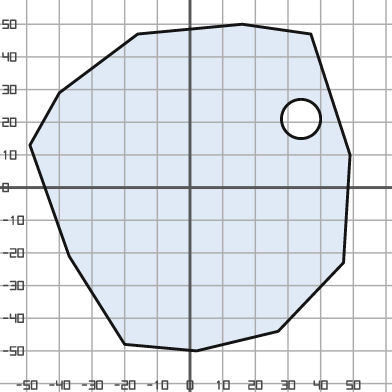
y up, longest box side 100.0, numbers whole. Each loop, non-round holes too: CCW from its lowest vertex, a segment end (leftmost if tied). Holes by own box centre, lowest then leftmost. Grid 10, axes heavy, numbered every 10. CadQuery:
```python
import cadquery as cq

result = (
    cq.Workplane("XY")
    .moveTo(2.0, -50.0)
    .lineTo(27.0, -44.0)
    .lineTo(47.0, -23.0)
    .lineTo(49.0, 10.0)
    .lineTo(37.0, 47.0)
    .lineTo(16.0, 50.0)
    .lineTo(-16.0, 47.0)
    .lineTo(-40.0, 29.0)
    .lineTo(-49.0, 13.0)
    .lineTo(-37.0, -21.0)
    .lineTo(-20.0, -48.0)
    .close()
    .moveTo(34.0, 21.0)
    .circle(6.0)
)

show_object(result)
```